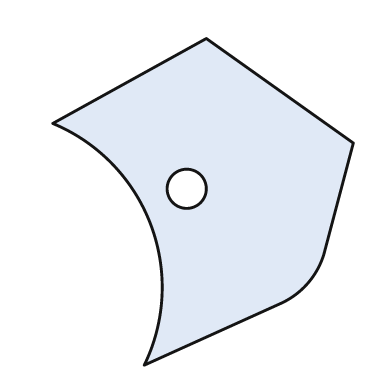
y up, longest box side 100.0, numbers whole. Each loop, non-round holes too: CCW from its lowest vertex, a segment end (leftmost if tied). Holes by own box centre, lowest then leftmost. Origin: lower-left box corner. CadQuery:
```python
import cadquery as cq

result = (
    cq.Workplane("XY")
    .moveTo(28.0, 0.0)
    .lineTo(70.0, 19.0)
    .threePointArc((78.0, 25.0), (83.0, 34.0))
    .lineTo(92.0, 68.0)
    .lineTo(47.0, 100.0)
    .lineTo(0.0, 74.0)
    .threePointArc((30.0, 43.0), (28.0, 0.0))
    .close()
    .moveTo(41.0, 54.0)
    .circle(6.0)
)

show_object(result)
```